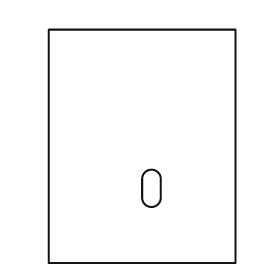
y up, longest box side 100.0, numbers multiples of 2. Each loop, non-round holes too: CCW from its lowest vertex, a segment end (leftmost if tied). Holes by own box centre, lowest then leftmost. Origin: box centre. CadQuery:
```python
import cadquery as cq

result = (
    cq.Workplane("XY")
    .moveTo(-40.0, -50.0)
    .lineTo(40.0, -50.0)
    .lineTo(40.0, 50.0)
    .lineTo(-40.0, 50.0)
    .close()
    .moveTo(0.0, -22.0)
    .threePointArc((4.0, -26.0), (8.0, -22.0))
    .lineTo(8.0, -14.0)
    .threePointArc((4.0, -10.0), (0.0, -14.0))
    .close()
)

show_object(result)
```